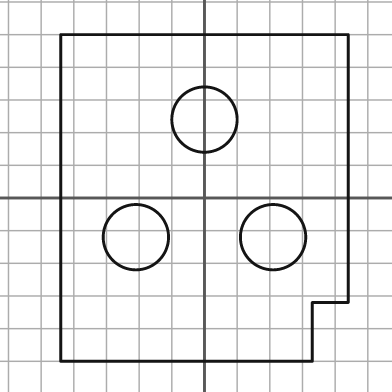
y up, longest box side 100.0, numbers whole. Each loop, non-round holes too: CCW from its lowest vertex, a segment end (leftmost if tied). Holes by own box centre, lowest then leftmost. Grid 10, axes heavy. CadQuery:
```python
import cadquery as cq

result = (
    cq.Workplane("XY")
    .moveTo(-44.0, -50.0)
    .lineTo(33.0, -50.0)
    .lineTo(33.0, -32.0)
    .lineTo(44.0, -32.0)
    .lineTo(44.0, 50.0)
    .lineTo(-44.0, 50.0)
    .close()
    .moveTo(-21.0, -12.0)
    .circle(10.0)
    .moveTo(21.0, -12.0)
    .circle(10.0)
    .moveTo(0.0, 24.0)
    .circle(10.0)
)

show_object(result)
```